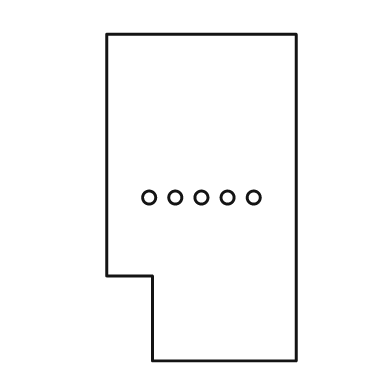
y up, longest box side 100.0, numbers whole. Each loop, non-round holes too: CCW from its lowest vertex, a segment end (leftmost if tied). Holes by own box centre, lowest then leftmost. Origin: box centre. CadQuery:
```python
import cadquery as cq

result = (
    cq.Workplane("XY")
    .moveTo(-15.0, -50.0)
    .lineTo(29.0, -50.0)
    .lineTo(29.0, 50.0)
    .lineTo(-29.0, 50.0)
    .lineTo(-29.0, -24.0)
    .lineTo(-15.0, -24.0)
    .close()
    .moveTo(-16.0, 0.0)
    .circle(2.0)
    .moveTo(-8.0, 0.0)
    .circle(2.0)
    .moveTo(0.0, 0.0)
    .circle(2.0)
    .moveTo(8.0, 0.0)
    .circle(2.0)
    .moveTo(16.0, 0.0)
    .circle(2.0)
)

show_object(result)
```